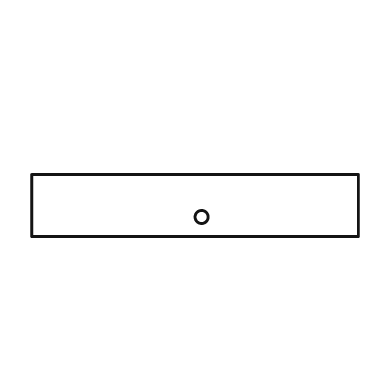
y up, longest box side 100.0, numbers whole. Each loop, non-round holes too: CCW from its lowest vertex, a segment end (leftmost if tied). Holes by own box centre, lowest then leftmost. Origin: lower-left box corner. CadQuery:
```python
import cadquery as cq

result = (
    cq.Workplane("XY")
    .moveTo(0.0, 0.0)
    .lineTo(100.0, 0.0)
    .lineTo(100.0, 19.0)
    .lineTo(0.0, 19.0)
    .close()
    .moveTo(52.0, 6.0)
    .circle(2.0)
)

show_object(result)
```